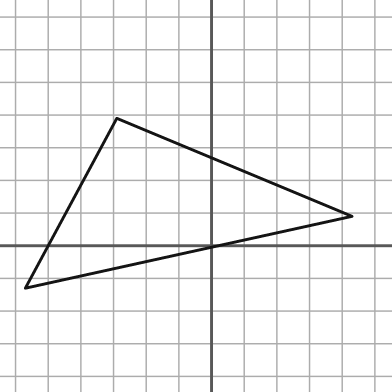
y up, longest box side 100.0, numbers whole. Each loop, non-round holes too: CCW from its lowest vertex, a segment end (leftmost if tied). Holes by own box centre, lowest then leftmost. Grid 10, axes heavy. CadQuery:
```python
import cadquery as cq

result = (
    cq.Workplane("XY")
    .moveTo(-57.0, -13.0)
    .lineTo(43.0, 9.0)
    .lineTo(-29.0, 39.0)
    .close()
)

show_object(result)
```